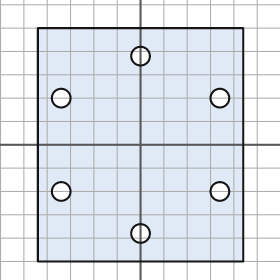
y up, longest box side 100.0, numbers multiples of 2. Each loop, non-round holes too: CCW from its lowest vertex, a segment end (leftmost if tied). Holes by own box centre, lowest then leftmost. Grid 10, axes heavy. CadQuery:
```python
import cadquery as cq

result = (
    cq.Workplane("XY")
    .moveTo(-44.0, -50.0)
    .lineTo(44.0, -50.0)
    .lineTo(44.0, 50.0)
    .lineTo(-44.0, 50.0)
    .close()
    .moveTo(0.0, -38.0)
    .circle(4.0)
    .moveTo(-34.0, -20.0)
    .circle(4.0)
    .moveTo(34.0, -20.0)
    .circle(4.0)
    .moveTo(-34.0, 20.0)
    .circle(4.0)
    .moveTo(34.0, 20.0)
    .circle(4.0)
    .moveTo(0.0, 38.0)
    .circle(4.0)
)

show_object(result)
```